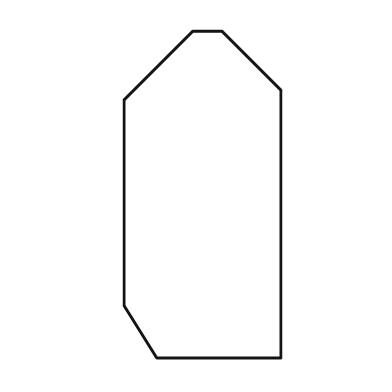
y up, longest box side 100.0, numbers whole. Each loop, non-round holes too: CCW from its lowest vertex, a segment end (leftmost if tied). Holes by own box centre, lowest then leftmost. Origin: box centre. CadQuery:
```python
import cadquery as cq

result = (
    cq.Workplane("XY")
    .moveTo(-14.0, -50.0)
    .lineTo(24.0, -50.0)
    .lineTo(24.0, 32.0)
    .lineTo(6.0, 50.0)
    .lineTo(-3.0, 50.0)
    .lineTo(-24.0, 29.0)
    .lineTo(-24.0, -34.0)
    .close()
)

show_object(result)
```